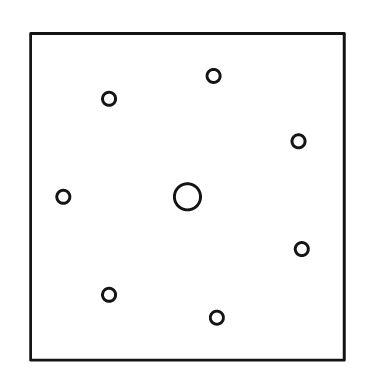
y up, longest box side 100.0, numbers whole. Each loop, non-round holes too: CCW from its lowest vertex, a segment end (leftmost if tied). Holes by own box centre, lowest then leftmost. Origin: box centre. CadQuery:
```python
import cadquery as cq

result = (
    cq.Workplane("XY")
    .moveTo(-48.0, -50.0)
    .lineTo(48.0, -50.0)
    .lineTo(48.0, 50.0)
    .lineTo(-48.0, 50.0)
    .close()
    .moveTo(9.0, -37.0)
    .circle(2.0)
    .moveTo(-24.0, -30.0)
    .circle(2.0)
    .moveTo(35.0, -16.0)
    .circle(2.0)
    .moveTo(-38.0, 0.0)
    .circle(2.0)
    .moveTo(0.0, 0.0)
    .circle(4.0)
    .moveTo(34.0, 17.0)
    .circle(2.0)
    .moveTo(-24.0, 30.0)
    .circle(2.0)
    .moveTo(8.0, 37.0)
    .circle(2.0)
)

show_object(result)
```